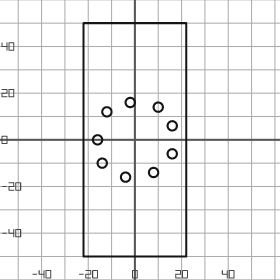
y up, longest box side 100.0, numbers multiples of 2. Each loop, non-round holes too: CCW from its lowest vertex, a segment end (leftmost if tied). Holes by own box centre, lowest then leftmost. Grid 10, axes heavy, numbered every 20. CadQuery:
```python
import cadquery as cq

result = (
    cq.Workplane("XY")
    .moveTo(-22.0, -50.0)
    .lineTo(22.0, -50.0)
    .lineTo(22.0, 50.0)
    .lineTo(-22.0, 50.0)
    .close()
    .moveTo(-4.0, -16.0)
    .circle(2.0)
    .moveTo(8.0, -14.0)
    .circle(2.0)
    .moveTo(-14.0, -10.0)
    .circle(2.0)
    .moveTo(16.0, -6.0)
    .circle(2.0)
    .moveTo(-16.0, 0.0)
    .circle(2.0)
    .moveTo(16.0, 6.0)
    .circle(2.0)
    .moveTo(-12.0, 12.0)
    .circle(2.0)
    .moveTo(10.0, 14.0)
    .circle(2.0)
    .moveTo(-2.0, 16.0)
    .circle(2.0)
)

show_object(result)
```